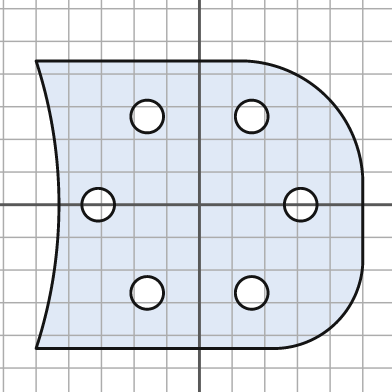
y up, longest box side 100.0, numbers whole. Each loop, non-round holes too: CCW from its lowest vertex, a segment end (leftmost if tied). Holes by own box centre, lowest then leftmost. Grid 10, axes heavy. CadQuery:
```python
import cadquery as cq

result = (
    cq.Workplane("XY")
    .moveTo(-50.0, -44.0)
    .lineTo(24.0, -44.0)
    .threePointArc((42.0, -36.0), (50.0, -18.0))
    .lineTo(50.0, 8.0)
    .threePointArc((39.0, 33.0), (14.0, 44.0))
    .lineTo(-50.0, 44.0)
    .threePointArc((-43.0, 0.0), (-50.0, -44.0))
    .close()
    .moveTo(-16.0, -27.0)
    .circle(5.0)
    .moveTo(16.0, -27.0)
    .circle(5.0)
    .moveTo(-31.0, 0.0)
    .circle(5.0)
    .moveTo(31.0, 0.0)
    .circle(5.0)
    .moveTo(-16.0, 27.0)
    .circle(5.0)
    .moveTo(16.0, 27.0)
    .circle(5.0)
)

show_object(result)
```